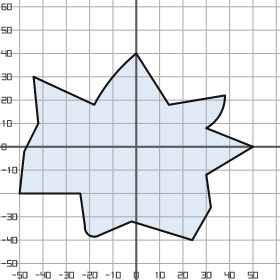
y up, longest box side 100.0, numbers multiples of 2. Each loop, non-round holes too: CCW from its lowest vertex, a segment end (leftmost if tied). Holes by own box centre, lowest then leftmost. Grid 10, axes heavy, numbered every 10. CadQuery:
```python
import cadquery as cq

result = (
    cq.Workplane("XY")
    .moveTo(24.0, -40.0)
    .lineTo(32.0, -26.0)
    .lineTo(30.0, -12.0)
    .lineTo(50.0, 0.0)
    .lineTo(30.0, 8.0)
    .threePointArc((36.0, 14.0), (38.0, 22.0))
    .lineTo(14.0, 18.0)
    .lineTo(0.0, 40.0)
    .threePointArc((-10.0, 30.0), (-18.0, 18.0))
    .lineTo(-44.0, 30.0)
    .lineTo(-42.0, 10.0)
    .lineTo(-48.0, -2.0)
    .lineTo(-50.0, -20.0)
    .lineTo(-24.0, -20.0)
    .lineTo(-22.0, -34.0)
    .threePointArc((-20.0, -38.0), (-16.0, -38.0))
    .lineTo(-2.0, -32.0)
    .close()
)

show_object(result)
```